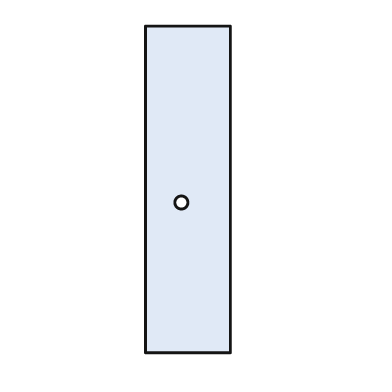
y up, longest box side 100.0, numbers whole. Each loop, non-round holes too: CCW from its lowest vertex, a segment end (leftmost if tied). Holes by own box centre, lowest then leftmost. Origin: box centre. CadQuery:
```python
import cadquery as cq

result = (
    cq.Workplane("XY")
    .moveTo(-13.0, -50.0)
    .lineTo(13.0, -50.0)
    .lineTo(13.0, 50.0)
    .lineTo(-13.0, 50.0)
    .close()
    .moveTo(-2.0, -4.0)
    .circle(2.0)
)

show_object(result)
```